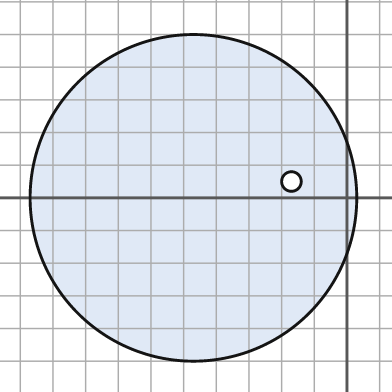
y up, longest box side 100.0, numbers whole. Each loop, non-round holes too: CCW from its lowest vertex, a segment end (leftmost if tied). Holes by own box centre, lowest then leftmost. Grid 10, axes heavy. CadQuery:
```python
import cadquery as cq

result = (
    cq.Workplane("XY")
    .moveTo(-47.0, 0.0)
    .circle(50.0)
    .moveTo(-17.0, 5.0)
    .circle(3.0)
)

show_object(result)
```